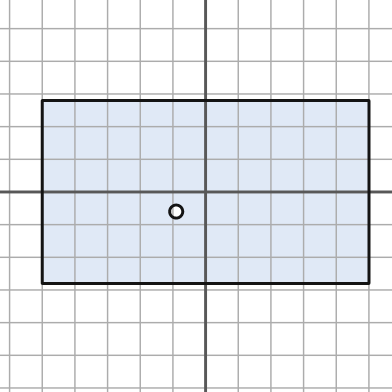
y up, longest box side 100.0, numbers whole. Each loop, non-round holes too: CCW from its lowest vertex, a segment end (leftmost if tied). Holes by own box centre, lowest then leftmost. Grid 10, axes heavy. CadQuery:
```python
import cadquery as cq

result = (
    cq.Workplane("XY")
    .moveTo(-50.0, -28.0)
    .lineTo(50.0, -28.0)
    .lineTo(50.0, 28.0)
    .lineTo(-50.0, 28.0)
    .close()
    .moveTo(-9.0, -6.0)
    .circle(2.0)
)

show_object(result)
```